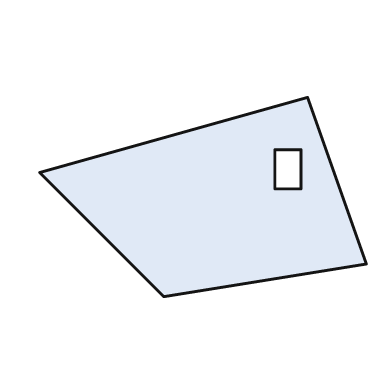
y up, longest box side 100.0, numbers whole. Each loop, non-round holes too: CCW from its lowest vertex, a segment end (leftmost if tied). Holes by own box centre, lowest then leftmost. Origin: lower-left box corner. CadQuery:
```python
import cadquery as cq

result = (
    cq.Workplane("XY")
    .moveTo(38.0, 0.0)
    .lineTo(100.0, 10.0)
    .lineTo(82.0, 61.0)
    .lineTo(0.0, 38.0)
    .close()
    .moveTo(72.0, 33.0)
    .lineTo(80.0, 33.0)
    .lineTo(80.0, 45.0)
    .lineTo(72.0, 45.0)
    .close()
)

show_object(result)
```